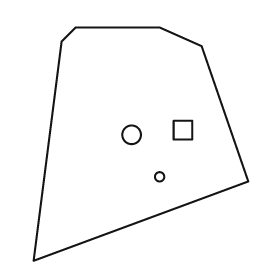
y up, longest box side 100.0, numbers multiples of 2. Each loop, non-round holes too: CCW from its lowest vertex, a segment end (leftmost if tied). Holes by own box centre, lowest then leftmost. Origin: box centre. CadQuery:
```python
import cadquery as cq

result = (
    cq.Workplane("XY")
    .moveTo(-46.0, -50.0)
    .lineTo(46.0, -16.0)
    .lineTo(26.0, 42.0)
    .lineTo(8.0, 50.0)
    .lineTo(-28.0, 50.0)
    .lineTo(-34.0, 44.0)
    .close()
    .moveTo(8.0, -14.0)
    .circle(2.0)
    .moveTo(-4.0, 4.0)
    .circle(4.0)
    .moveTo(14.0, 2.0)
    .lineTo(22.0, 2.0)
    .lineTo(22.0, 10.0)
    .lineTo(14.0, 10.0)
    .close()
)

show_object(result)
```